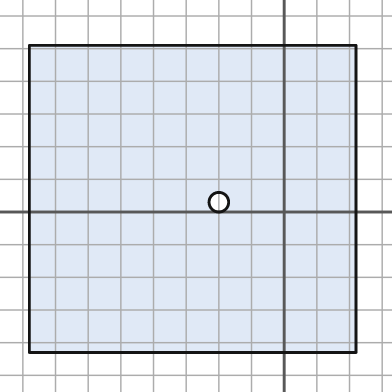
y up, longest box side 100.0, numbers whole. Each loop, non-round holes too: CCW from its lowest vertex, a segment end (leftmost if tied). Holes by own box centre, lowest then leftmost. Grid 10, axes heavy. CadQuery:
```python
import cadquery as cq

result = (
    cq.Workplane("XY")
    .moveTo(-78.0, -43.0)
    .lineTo(22.0, -43.0)
    .lineTo(22.0, 51.0)
    .lineTo(-78.0, 51.0)
    .close()
    .moveTo(-20.0, 3.0)
    .circle(3.0)
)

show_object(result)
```